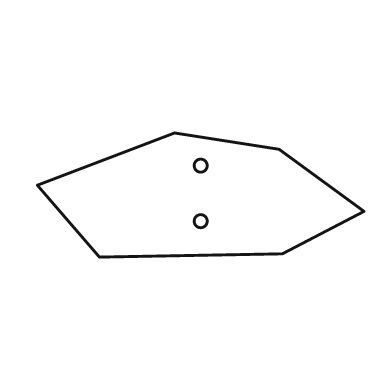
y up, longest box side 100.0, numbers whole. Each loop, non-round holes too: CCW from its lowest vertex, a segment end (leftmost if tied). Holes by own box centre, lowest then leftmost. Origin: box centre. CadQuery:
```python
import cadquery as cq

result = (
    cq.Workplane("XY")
    .moveTo(-31.0, -19.0)
    .lineTo(25.0, -18.0)
    .lineTo(50.0, -5.0)
    .lineTo(24.0, 14.0)
    .lineTo(-8.0, 19.0)
    .lineTo(-50.0, 3.0)
    .close()
    .moveTo(0.0, -8.0)
    .circle(2.0)
    .moveTo(0.0, 9.0)
    .circle(2.0)
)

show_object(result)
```